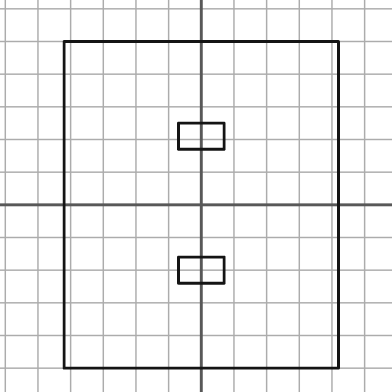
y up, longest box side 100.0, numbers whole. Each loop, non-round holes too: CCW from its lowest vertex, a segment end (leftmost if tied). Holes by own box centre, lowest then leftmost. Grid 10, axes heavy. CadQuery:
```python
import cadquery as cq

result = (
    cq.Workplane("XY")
    .moveTo(-42.0, -50.0)
    .lineTo(42.0, -50.0)
    .lineTo(42.0, 50.0)
    .lineTo(-42.0, 50.0)
    .close()
    .moveTo(-7.0, -24.0)
    .lineTo(7.0, -24.0)
    .lineTo(7.0, -16.0)
    .lineTo(-7.0, -16.0)
    .close()
    .moveTo(-7.0, 17.0)
    .lineTo(7.0, 17.0)
    .lineTo(7.0, 25.0)
    .lineTo(-7.0, 25.0)
    .close()
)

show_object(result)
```